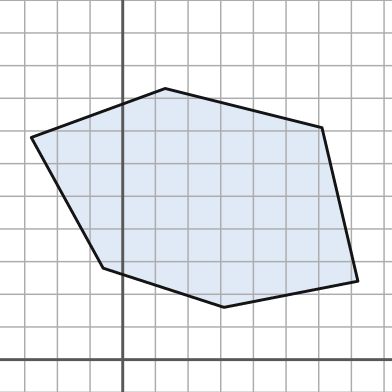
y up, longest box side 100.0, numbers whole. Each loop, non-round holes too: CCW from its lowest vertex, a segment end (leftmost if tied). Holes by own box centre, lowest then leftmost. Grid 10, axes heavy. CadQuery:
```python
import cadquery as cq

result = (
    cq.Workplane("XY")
    .moveTo(31.0, 16.0)
    .lineTo(72.0, 24.0)
    .lineTo(61.0, 71.0)
    .lineTo(13.0, 83.0)
    .lineTo(-28.0, 68.0)
    .lineTo(-6.0, 28.0)
    .close()
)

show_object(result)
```